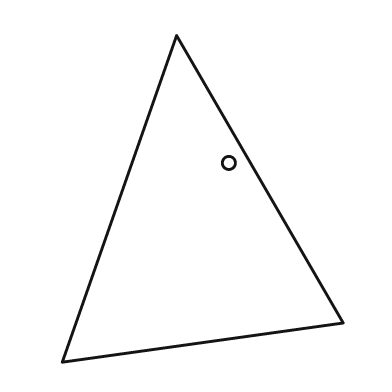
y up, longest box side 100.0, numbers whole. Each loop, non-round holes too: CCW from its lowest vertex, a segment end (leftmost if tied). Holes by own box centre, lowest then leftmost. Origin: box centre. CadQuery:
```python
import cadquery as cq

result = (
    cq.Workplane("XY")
    .moveTo(-43.0, -50.0)
    .lineTo(43.0, -38.0)
    .lineTo(-8.0, 50.0)
    .close()
    .moveTo(8.0, 11.0)
    .circle(2.0)
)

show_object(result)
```